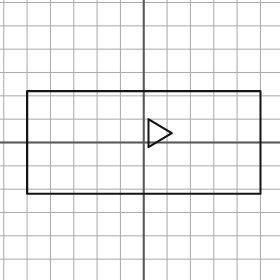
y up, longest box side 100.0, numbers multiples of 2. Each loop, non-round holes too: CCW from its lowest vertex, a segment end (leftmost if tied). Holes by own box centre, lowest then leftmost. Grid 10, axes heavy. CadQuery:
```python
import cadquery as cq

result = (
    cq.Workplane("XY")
    .moveTo(-50.0, -22.0)
    .lineTo(50.0, -22.0)
    .lineTo(50.0, 22.0)
    .lineTo(-50.0, 22.0)
    .close()
    .moveTo(2.0, -2.0)
    .lineTo(12.0, 4.0)
    .lineTo(2.0, 10.0)
    .close()
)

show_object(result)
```